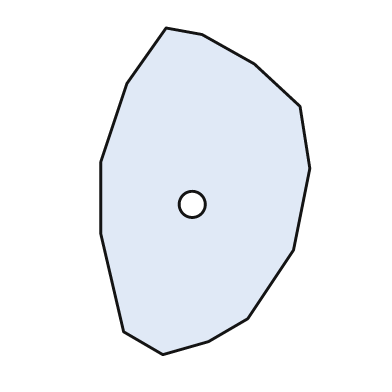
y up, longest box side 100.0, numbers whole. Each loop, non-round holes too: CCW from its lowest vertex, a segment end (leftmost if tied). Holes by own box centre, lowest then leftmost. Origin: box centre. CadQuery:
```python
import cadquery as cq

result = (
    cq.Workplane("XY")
    .moveTo(-13.0, -50.0)
    .lineTo(1.0, -46.0)
    .lineTo(13.0, -39.0)
    .lineTo(27.0, -18.0)
    .lineTo(32.0, 7.0)
    .lineTo(29.0, 26.0)
    .lineTo(15.0, 39.0)
    .lineTo(-1.0, 48.0)
    .lineTo(-12.0, 50.0)
    .lineTo(-24.0, 33.0)
    .lineTo(-32.0, 9.0)
    .lineTo(-32.0, -13.0)
    .lineTo(-25.0, -43.0)
    .close()
    .moveTo(-4.0, -4.0)
    .circle(4.0)
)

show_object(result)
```